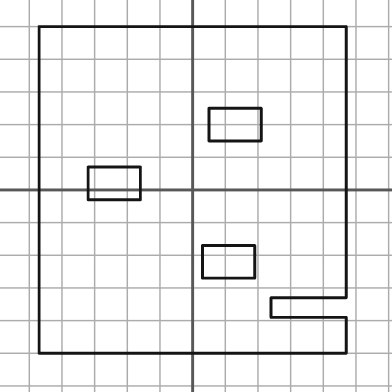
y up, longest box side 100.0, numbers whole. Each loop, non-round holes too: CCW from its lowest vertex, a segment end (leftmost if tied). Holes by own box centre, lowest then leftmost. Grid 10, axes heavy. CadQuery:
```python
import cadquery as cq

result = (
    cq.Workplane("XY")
    .moveTo(-47.0, -50.0)
    .lineTo(47.0, -50.0)
    .lineTo(47.0, -39.0)
    .lineTo(24.0, -39.0)
    .lineTo(24.0, -33.0)
    .lineTo(47.0, -33.0)
    .lineTo(47.0, 50.0)
    .lineTo(-47.0, 50.0)
    .close()
    .moveTo(3.0, -27.0)
    .lineTo(19.0, -27.0)
    .lineTo(19.0, -17.0)
    .lineTo(3.0, -17.0)
    .close()
    .moveTo(-32.0, -3.0)
    .lineTo(-16.0, -3.0)
    .lineTo(-16.0, 7.0)
    .lineTo(-32.0, 7.0)
    .close()
    .moveTo(5.0, 15.0)
    .lineTo(21.0, 15.0)
    .lineTo(21.0, 25.0)
    .lineTo(5.0, 25.0)
    .close()
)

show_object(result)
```